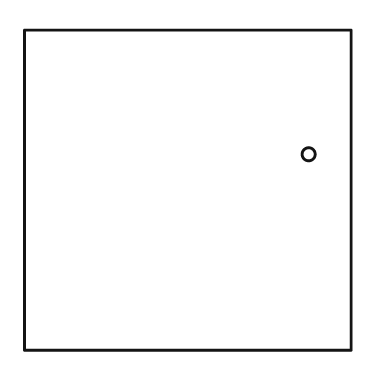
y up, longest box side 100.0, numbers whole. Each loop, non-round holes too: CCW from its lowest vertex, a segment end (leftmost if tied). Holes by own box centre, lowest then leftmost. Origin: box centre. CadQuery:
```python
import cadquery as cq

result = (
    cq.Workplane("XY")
    .moveTo(-50.0, -49.0)
    .lineTo(50.0, -49.0)
    .lineTo(50.0, 49.0)
    .lineTo(-50.0, 49.0)
    .close()
    .moveTo(37.0, 11.0)
    .circle(2.0)
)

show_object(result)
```